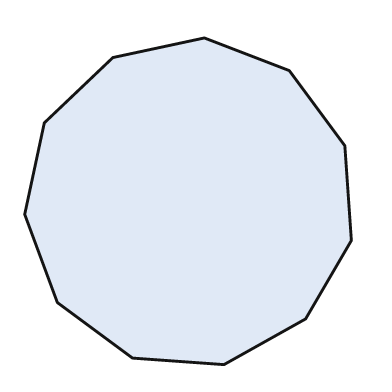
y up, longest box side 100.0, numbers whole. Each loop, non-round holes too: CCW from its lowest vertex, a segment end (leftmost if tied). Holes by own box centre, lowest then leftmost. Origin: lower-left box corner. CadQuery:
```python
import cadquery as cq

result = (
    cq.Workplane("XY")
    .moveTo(61.0, 0.0)
    .lineTo(86.0, 14.0)
    .lineTo(100.0, 38.0)
    .lineTo(98.0, 67.0)
    .lineTo(81.0, 90.0)
    .lineTo(55.0, 100.0)
    .lineTo(27.0, 94.0)
    .lineTo(6.0, 74.0)
    .lineTo(0.0, 46.0)
    .lineTo(10.0, 19.0)
    .lineTo(33.0, 2.0)
    .close()
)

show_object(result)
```